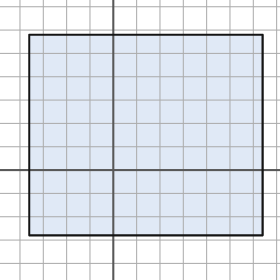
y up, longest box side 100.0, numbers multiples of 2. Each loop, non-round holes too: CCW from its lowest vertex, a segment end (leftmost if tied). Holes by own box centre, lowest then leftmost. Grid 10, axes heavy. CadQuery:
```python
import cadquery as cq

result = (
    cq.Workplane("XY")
    .moveTo(-36.0, -28.0)
    .lineTo(64.0, -28.0)
    .lineTo(64.0, 58.0)
    .lineTo(-36.0, 58.0)
    .close()
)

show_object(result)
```